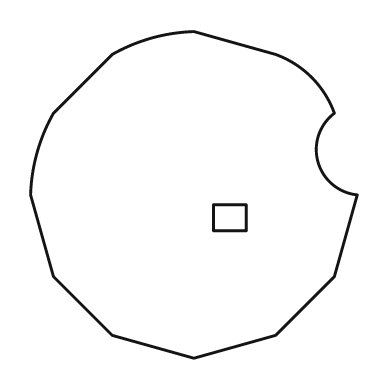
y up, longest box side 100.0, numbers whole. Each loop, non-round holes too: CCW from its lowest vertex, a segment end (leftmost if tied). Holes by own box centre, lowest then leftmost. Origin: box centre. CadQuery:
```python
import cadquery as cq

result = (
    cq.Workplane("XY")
    .moveTo(0.0, -50.0)
    .lineTo(25.0, -43.0)
    .lineTo(43.0, -25.0)
    .lineTo(50.0, 0.0)
    .threePointArc((38.0, 10.0), (43.0, 25.0))
    .threePointArc((36.0, 36.0), (25.0, 43.0))
    .lineTo(0.0, 50.0)
    .threePointArc((-13.0, 48.0), (-25.0, 43.0))
    .lineTo(-43.0, 25.0)
    .threePointArc((-48.0, 13.0), (-50.0, 0.0))
    .lineTo(-43.0, -25.0)
    .lineTo(-25.0, -43.0)
    .close()
    .moveTo(6.0, -11.0)
    .lineTo(16.0, -11.0)
    .lineTo(16.0, -3.0)
    .lineTo(6.0, -3.0)
    .close()
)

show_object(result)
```